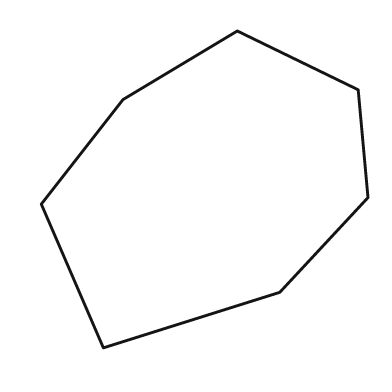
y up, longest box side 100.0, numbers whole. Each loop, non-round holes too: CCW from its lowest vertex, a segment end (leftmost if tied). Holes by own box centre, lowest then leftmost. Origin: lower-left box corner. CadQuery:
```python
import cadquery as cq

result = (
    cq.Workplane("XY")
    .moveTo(19.0, 0.0)
    .lineTo(73.0, 17.0)
    .lineTo(100.0, 46.0)
    .lineTo(97.0, 79.0)
    .lineTo(60.0, 97.0)
    .lineTo(25.0, 76.0)
    .lineTo(0.0, 44.0)
    .close()
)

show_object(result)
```